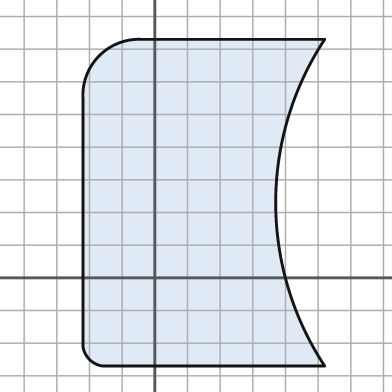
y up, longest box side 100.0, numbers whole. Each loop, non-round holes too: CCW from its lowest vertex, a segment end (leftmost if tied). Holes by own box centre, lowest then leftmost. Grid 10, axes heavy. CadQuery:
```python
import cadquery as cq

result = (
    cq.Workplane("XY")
    .moveTo(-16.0, -27.0)
    .lineTo(52.0, -27.0)
    .threePointArc((37.0, 23.0), (52.0, 73.0))
    .lineTo(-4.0, 73.0)
    .threePointArc((-17.0, 68.0), (-22.0, 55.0))
    .lineTo(-22.0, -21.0)
    .threePointArc((-20.0, -25.0), (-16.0, -27.0))
    .close()
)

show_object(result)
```